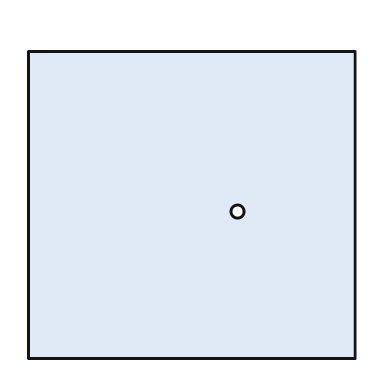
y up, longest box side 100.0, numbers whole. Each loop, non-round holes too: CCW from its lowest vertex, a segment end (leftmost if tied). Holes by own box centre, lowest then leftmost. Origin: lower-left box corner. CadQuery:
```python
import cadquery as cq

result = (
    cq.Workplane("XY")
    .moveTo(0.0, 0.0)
    .lineTo(100.0, 0.0)
    .lineTo(100.0, 94.0)
    .lineTo(0.0, 94.0)
    .close()
    .moveTo(64.0, 45.0)
    .circle(2.0)
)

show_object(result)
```